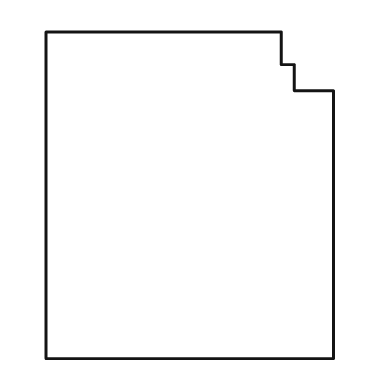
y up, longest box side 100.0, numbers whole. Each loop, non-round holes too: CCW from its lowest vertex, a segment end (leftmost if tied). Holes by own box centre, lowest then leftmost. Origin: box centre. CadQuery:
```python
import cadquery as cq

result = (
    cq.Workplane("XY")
    .moveTo(-44.0, -50.0)
    .lineTo(44.0, -50.0)
    .lineTo(44.0, 32.0)
    .lineTo(32.0, 32.0)
    .lineTo(32.0, 40.0)
    .lineTo(28.0, 40.0)
    .lineTo(28.0, 50.0)
    .lineTo(-44.0, 50.0)
    .close()
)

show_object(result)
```